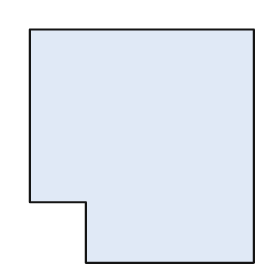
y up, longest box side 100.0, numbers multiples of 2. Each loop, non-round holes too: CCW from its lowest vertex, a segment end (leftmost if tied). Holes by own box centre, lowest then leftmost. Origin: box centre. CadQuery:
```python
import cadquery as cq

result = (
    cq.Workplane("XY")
    .moveTo(-24.0, -50.0)
    .lineTo(48.0, -50.0)
    .lineTo(48.0, 50.0)
    .lineTo(-48.0, 50.0)
    .lineTo(-48.0, -24.0)
    .lineTo(-24.0, -24.0)
    .close()
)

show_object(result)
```